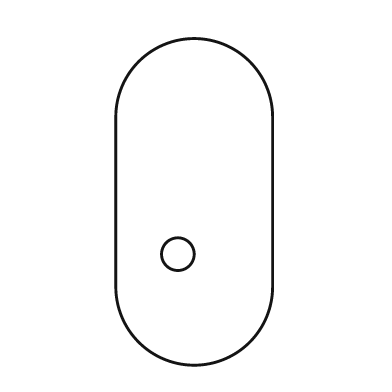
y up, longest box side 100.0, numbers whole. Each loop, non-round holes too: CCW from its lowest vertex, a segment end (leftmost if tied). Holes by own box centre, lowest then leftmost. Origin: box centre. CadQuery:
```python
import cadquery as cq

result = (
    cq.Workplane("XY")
    .moveTo(-24.0, -26.0)
    .threePointArc((0.0, -50.0), (24.0, -26.0))
    .lineTo(24.0, 26.0)
    .threePointArc((0.0, 50.0), (-24.0, 26.0))
    .close()
    .moveTo(-5.0, -16.0)
    .circle(5.0)
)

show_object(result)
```